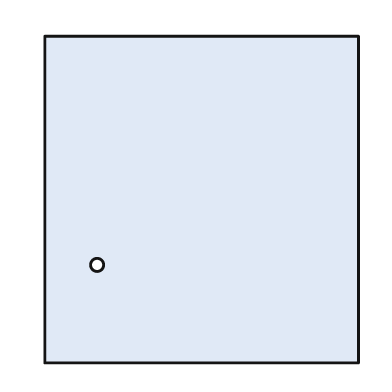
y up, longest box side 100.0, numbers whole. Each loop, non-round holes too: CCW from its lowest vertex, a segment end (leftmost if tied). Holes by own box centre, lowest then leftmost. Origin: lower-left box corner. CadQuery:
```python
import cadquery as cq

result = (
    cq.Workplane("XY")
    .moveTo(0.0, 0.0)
    .lineTo(96.0, 0.0)
    .lineTo(96.0, 100.0)
    .lineTo(0.0, 100.0)
    .close()
    .moveTo(16.0, 30.0)
    .circle(2.0)
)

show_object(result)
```